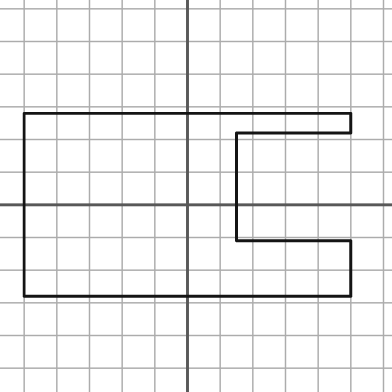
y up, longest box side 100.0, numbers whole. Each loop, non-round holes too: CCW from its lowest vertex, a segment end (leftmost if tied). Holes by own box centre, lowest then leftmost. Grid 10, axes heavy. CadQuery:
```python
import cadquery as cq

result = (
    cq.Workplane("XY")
    .moveTo(-50.0, -28.0)
    .lineTo(50.0, -28.0)
    .lineTo(50.0, -11.0)
    .lineTo(15.0, -11.0)
    .lineTo(15.0, 22.0)
    .lineTo(50.0, 22.0)
    .lineTo(50.0, 28.0)
    .lineTo(-50.0, 28.0)
    .close()
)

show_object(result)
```